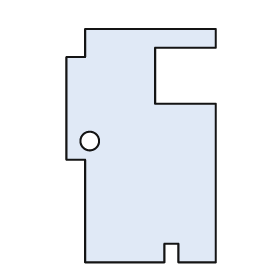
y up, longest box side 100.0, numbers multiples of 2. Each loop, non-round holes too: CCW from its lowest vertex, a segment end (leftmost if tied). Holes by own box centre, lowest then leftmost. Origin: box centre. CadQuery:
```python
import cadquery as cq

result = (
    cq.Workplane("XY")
    .moveTo(-24.0, -50.0)
    .lineTo(10.0, -50.0)
    .lineTo(10.0, -42.0)
    .lineTo(16.0, -42.0)
    .lineTo(16.0, -50.0)
    .lineTo(32.0, -50.0)
    .lineTo(32.0, 18.0)
    .lineTo(6.0, 18.0)
    .lineTo(6.0, 42.0)
    .lineTo(32.0, 42.0)
    .lineTo(32.0, 50.0)
    .lineTo(-24.0, 50.0)
    .lineTo(-24.0, 38.0)
    .lineTo(-32.0, 38.0)
    .lineTo(-32.0, -6.0)
    .lineTo(-24.0, -6.0)
    .close()
    .moveTo(-22.0, 2.0)
    .circle(4.0)
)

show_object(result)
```